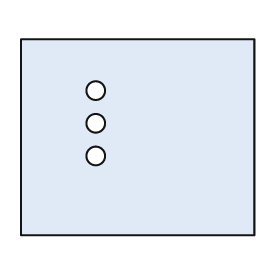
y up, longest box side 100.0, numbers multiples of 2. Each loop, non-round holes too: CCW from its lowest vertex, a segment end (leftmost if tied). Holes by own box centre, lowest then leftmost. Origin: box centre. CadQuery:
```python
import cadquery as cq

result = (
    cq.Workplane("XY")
    .moveTo(-50.0, -42.0)
    .lineTo(50.0, -42.0)
    .lineTo(50.0, 42.0)
    .lineTo(-50.0, 42.0)
    .close()
    .moveTo(-18.0, -8.0)
    .circle(4.0)
    .moveTo(-18.0, 6.0)
    .circle(4.0)
    .moveTo(-18.0, 20.0)
    .circle(4.0)
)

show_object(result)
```